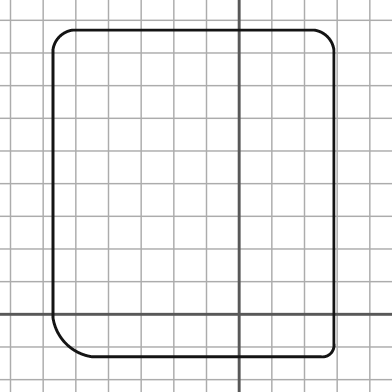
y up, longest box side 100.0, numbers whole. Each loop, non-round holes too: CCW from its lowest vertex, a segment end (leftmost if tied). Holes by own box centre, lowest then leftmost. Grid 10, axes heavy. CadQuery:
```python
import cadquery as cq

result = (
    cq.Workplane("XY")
    .moveTo(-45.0, -13.0)
    .lineTo(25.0, -13.0)
    .threePointArc((28.0, -12.0), (29.0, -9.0))
    .lineTo(29.0, 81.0)
    .threePointArc((27.0, 85.0), (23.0, 87.0))
    .lineTo(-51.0, 87.0)
    .threePointArc((-55.0, 85.0), (-57.0, 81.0))
    .lineTo(-57.0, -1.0)
    .threePointArc((-53.0, -9.0), (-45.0, -13.0))
    .close()
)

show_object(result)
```